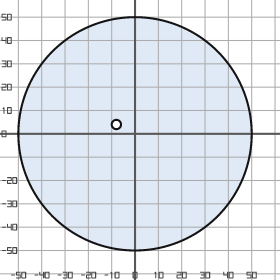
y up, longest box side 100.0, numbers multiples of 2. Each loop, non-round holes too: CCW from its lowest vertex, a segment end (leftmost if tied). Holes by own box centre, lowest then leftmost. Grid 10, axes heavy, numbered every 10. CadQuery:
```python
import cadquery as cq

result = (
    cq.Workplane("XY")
    .moveTo(0.0, 0.0)
    .circle(50.0)
    .moveTo(-8.0, 4.0)
    .circle(2.0)
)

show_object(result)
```